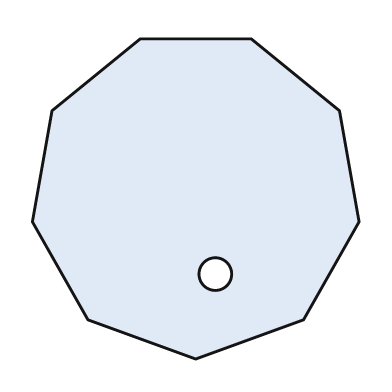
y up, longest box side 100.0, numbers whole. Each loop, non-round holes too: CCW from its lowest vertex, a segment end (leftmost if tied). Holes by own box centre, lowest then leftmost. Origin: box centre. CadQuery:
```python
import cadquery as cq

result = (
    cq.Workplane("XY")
    .moveTo(0.0, -49.0)
    .lineTo(33.0, -37.0)
    .lineTo(50.0, -7.0)
    .lineTo(44.0, 27.0)
    .lineTo(17.0, 49.0)
    .lineTo(-17.0, 49.0)
    .lineTo(-44.0, 27.0)
    .lineTo(-50.0, -7.0)
    .lineTo(-33.0, -37.0)
    .close()
    .moveTo(6.0, -23.0)
    .circle(5.0)
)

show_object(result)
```